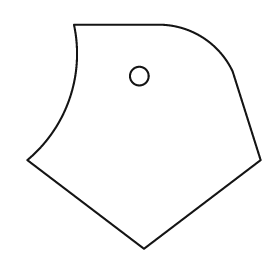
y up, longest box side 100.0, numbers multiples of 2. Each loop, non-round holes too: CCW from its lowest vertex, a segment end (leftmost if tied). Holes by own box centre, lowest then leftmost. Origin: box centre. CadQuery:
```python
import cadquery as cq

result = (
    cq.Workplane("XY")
    .moveTo(0.0, -48.0)
    .lineTo(50.0, -10.0)
    .lineTo(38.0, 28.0)
    .threePointArc((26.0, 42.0), (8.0, 48.0))
    .lineTo(-30.0, 48.0)
    .threePointArc((-32.0, 16.0), (-50.0, -10.0))
    .close()
    .moveTo(-2.0, 26.0)
    .circle(4.0)
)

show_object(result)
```